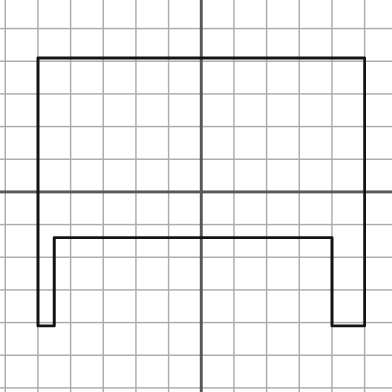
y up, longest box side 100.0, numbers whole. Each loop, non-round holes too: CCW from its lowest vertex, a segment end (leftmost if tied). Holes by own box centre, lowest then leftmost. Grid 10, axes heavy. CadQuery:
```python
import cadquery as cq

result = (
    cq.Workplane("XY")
    .moveTo(-50.0, -41.0)
    .lineTo(-45.0, -41.0)
    .lineTo(-45.0, -14.0)
    .lineTo(40.0, -14.0)
    .lineTo(40.0, -41.0)
    .lineTo(50.0, -41.0)
    .lineTo(50.0, 41.0)
    .lineTo(-50.0, 41.0)
    .close()
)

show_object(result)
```